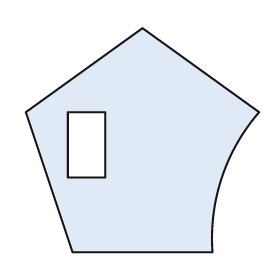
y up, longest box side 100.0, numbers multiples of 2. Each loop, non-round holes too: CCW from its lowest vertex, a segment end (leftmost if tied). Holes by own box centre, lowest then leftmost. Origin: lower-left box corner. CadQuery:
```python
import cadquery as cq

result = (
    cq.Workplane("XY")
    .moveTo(20.0, 0.0)
    .lineTo(80.0, 0.0)
    .threePointArc((84.0, 32.0), (100.0, 60.0))
    .lineTo(50.0, 96.0)
    .lineTo(0.0, 60.0)
    .close()
    .moveTo(18.0, 32.0)
    .lineTo(34.0, 32.0)
    .lineTo(34.0, 60.0)
    .lineTo(18.0, 60.0)
    .close()
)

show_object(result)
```